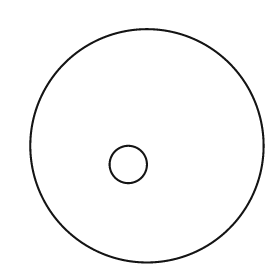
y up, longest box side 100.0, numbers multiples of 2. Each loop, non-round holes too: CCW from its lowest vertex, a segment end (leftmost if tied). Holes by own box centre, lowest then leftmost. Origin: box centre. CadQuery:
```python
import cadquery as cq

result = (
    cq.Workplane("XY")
    .moveTo(0.0, 0.0)
    .circle(50.0)
    .moveTo(-8.0, -8.0)
    .circle(8.0)
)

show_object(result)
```